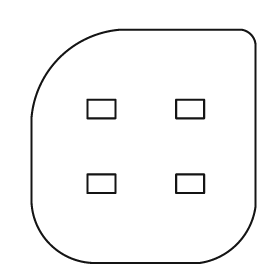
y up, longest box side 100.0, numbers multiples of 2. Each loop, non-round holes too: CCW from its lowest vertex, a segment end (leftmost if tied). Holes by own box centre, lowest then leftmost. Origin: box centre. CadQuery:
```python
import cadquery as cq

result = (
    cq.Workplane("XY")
    .moveTo(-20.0, -50.0)
    .lineTo(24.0, -50.0)
    .threePointArc((40.0, -42.0), (48.0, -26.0))
    .lineTo(48.0, 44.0)
    .threePointArc((46.0, 48.0), (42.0, 50.0))
    .lineTo(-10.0, 50.0)
    .threePointArc((-36.0, 38.0), (-48.0, 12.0))
    .lineTo(-48.0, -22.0)
    .threePointArc((-40.0, -42.0), (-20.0, -50.0))
    .close()
    .moveTo(-24.0, -20.0)
    .lineTo(-12.0, -20.0)
    .lineTo(-12.0, -12.0)
    .lineTo(-24.0, -12.0)
    .close()
    .moveTo(14.0, -20.0)
    .lineTo(26.0, -20.0)
    .lineTo(26.0, -12.0)
    .lineTo(14.0, -12.0)
    .close()
    .moveTo(-24.0, 12.0)
    .lineTo(-12.0, 12.0)
    .lineTo(-12.0, 20.0)
    .lineTo(-24.0, 20.0)
    .close()
    .moveTo(14.0, 12.0)
    .lineTo(26.0, 12.0)
    .lineTo(26.0, 20.0)
    .lineTo(14.0, 20.0)
    .close()
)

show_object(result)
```